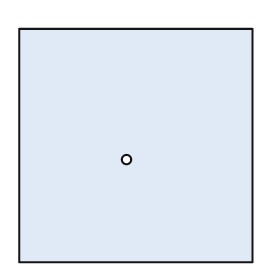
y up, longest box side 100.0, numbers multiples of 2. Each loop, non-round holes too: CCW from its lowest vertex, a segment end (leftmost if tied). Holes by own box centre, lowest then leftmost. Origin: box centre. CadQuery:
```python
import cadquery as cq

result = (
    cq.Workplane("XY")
    .moveTo(-50.0, -50.0)
    .lineTo(50.0, -50.0)
    .lineTo(50.0, 50.0)
    .lineTo(-50.0, 50.0)
    .close()
    .moveTo(-4.0, -6.0)
    .circle(2.0)
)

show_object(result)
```